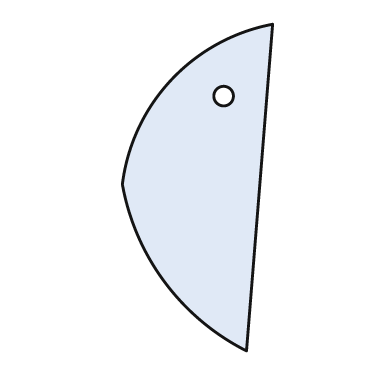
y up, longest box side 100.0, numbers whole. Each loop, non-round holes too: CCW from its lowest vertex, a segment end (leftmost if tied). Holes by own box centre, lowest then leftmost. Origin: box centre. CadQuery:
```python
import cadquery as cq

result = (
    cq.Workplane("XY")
    .moveTo(15.0, -50.0)
    .lineTo(23.0, 50.0)
    .threePointArc((-8.0, 33.0), (-23.0, 1.0))
    .threePointArc((-10.0, -29.0), (15.0, -50.0))
    .close()
    .moveTo(8.0, 28.0)
    .circle(3.0)
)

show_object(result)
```